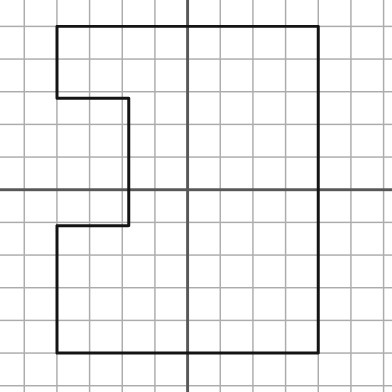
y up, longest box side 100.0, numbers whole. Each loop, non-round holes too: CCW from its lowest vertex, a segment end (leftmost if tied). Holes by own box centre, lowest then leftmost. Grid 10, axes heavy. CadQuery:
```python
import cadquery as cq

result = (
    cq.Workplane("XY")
    .moveTo(-40.0, -50.0)
    .lineTo(40.0, -50.0)
    .lineTo(40.0, 50.0)
    .lineTo(-40.0, 50.0)
    .lineTo(-40.0, 28.0)
    .lineTo(-18.0, 28.0)
    .lineTo(-18.0, -11.0)
    .lineTo(-40.0, -11.0)
    .close()
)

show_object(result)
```